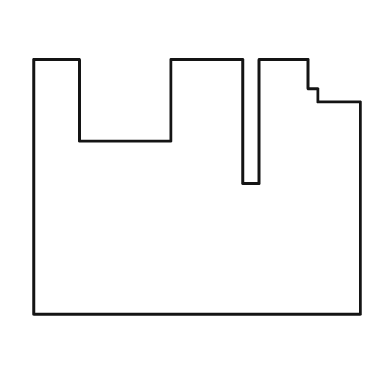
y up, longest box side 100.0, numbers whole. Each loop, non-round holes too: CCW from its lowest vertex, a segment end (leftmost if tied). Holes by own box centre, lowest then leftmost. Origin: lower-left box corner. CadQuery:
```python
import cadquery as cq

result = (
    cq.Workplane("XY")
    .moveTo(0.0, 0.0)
    .lineTo(100.0, 0.0)
    .lineTo(100.0, 65.0)
    .lineTo(87.0, 65.0)
    .lineTo(87.0, 69.0)
    .lineTo(84.0, 69.0)
    .lineTo(84.0, 78.0)
    .lineTo(69.0, 78.0)
    .lineTo(69.0, 40.0)
    .lineTo(64.0, 40.0)
    .lineTo(64.0, 78.0)
    .lineTo(42.0, 78.0)
    .lineTo(42.0, 53.0)
    .lineTo(14.0, 53.0)
    .lineTo(14.0, 78.0)
    .lineTo(0.0, 78.0)
    .close()
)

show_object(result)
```